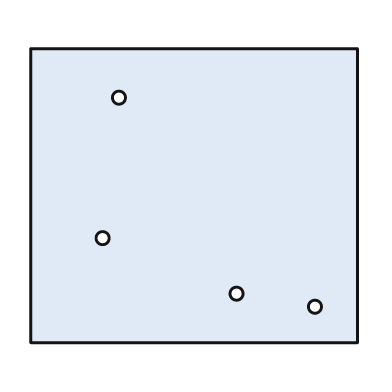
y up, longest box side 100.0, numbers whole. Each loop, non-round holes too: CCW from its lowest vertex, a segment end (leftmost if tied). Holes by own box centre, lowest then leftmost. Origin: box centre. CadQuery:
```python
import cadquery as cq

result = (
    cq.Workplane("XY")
    .moveTo(-50.0, -45.0)
    .lineTo(50.0, -45.0)
    .lineTo(50.0, 45.0)
    .lineTo(-50.0, 45.0)
    .close()
    .moveTo(37.0, -34.0)
    .circle(2.0)
    .moveTo(13.0, -30.0)
    .circle(2.0)
    .moveTo(-28.0, -13.0)
    .circle(2.0)
    .moveTo(-23.0, 30.0)
    .circle(2.0)
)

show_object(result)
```